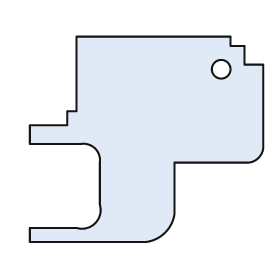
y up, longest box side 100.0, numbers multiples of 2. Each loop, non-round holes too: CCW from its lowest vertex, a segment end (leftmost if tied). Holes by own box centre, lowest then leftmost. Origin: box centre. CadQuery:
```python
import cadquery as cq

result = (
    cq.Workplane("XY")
    .moveTo(-50.0, -44.0)
    .lineTo(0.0, -44.0)
    .threePointArc((8.0, -40.0), (12.0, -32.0))
    .lineTo(12.0, -10.0)
    .lineTo(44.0, -10.0)
    .threePointArc((48.0, -8.0), (50.0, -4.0))
    .lineTo(50.0, 32.0)
    .lineTo(42.0, 32.0)
    .lineTo(42.0, 40.0)
    .lineTo(36.0, 40.0)
    .lineTo(36.0, 44.0)
    .lineTo(-30.0, 44.0)
    .lineTo(-30.0, 12.0)
    .lineTo(-34.0, 12.0)
    .lineTo(-34.0, 6.0)
    .lineTo(-50.0, 6.0)
    .lineTo(-50.0, -2.0)
    .lineTo(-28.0, -2.0)
    .threePointArc((-22.0, -4.0), (-20.0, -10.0))
    .lineTo(-20.0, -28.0)
    .threePointArc((-22.0, -36.0), (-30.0, -38.0))
    .lineTo(-50.0, -38.0)
    .close()
    .moveTo(32.0, 30.0)
    .circle(4.0)
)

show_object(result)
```